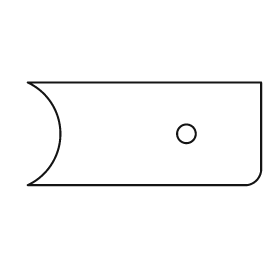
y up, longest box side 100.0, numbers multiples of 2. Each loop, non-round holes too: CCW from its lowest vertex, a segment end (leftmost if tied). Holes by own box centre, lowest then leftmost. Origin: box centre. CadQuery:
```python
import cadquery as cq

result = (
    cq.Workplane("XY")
    .moveTo(-50.0, -22.0)
    .lineTo(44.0, -22.0)
    .threePointArc((48.0, -20.0), (50.0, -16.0))
    .lineTo(50.0, 22.0)
    .lineTo(-50.0, 22.0)
    .threePointArc((-36.0, 0.0), (-50.0, -22.0))
    .close()
    .moveTo(18.0, 0.0)
    .circle(4.0)
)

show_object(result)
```